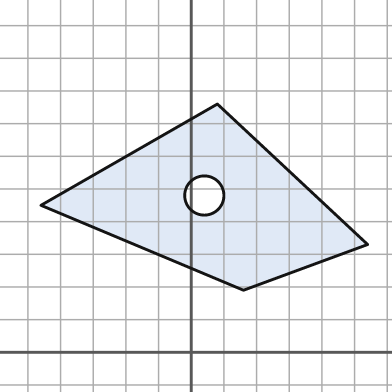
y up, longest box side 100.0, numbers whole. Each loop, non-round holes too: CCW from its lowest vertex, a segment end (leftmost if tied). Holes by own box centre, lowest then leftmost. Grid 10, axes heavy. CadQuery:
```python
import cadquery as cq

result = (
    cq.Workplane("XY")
    .moveTo(16.0, 19.0)
    .lineTo(54.0, 33.0)
    .lineTo(8.0, 76.0)
    .lineTo(-46.0, 45.0)
    .close()
    .moveTo(4.0, 48.0)
    .circle(6.0)
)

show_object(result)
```